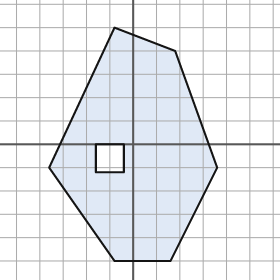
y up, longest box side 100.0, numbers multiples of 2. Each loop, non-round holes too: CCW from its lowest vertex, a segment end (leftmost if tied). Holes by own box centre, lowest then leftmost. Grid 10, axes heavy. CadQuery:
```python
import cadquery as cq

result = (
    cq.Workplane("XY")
    .moveTo(-8.0, -50.0)
    .lineTo(16.0, -50.0)
    .lineTo(36.0, -10.0)
    .lineTo(18.0, 40.0)
    .lineTo(-8.0, 50.0)
    .lineTo(-36.0, -10.0)
    .close()
    .moveTo(-16.0, -12.0)
    .lineTo(-4.0, -12.0)
    .lineTo(-4.0, 0.0)
    .lineTo(-16.0, 0.0)
    .close()
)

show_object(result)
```